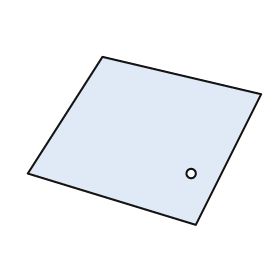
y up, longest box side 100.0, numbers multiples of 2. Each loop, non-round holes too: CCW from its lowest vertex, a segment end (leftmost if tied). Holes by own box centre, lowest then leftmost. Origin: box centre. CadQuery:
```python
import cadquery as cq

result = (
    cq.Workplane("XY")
    .moveTo(22.0, -36.0)
    .lineTo(50.0, 20.0)
    .lineTo(-18.0, 36.0)
    .lineTo(-50.0, -14.0)
    .close()
    .moveTo(20.0, -14.0)
    .circle(2.0)
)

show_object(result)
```